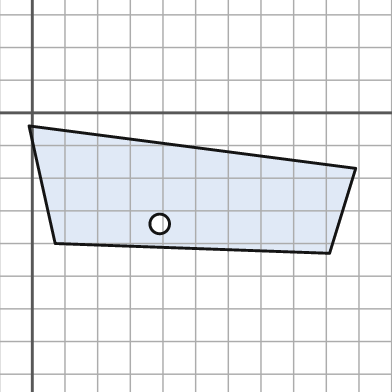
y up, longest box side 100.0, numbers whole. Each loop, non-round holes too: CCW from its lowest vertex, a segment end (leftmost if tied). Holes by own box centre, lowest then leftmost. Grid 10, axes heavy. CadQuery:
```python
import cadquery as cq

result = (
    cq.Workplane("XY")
    .moveTo(91.0, -43.0)
    .lineTo(99.0, -17.0)
    .lineTo(-1.0, -4.0)
    .lineTo(7.0, -40.0)
    .close()
    .moveTo(39.0, -34.0)
    .circle(3.0)
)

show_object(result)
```